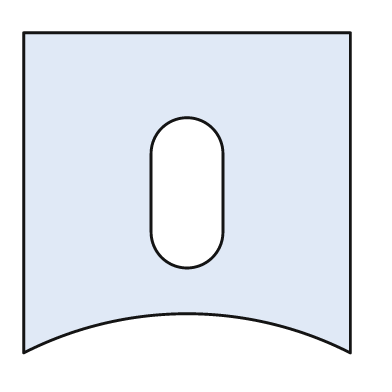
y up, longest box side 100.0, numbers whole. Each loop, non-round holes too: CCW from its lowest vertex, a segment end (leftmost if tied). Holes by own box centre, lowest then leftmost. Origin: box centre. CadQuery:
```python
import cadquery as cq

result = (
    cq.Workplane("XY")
    .moveTo(-50.0, -49.0)
    .threePointArc((0.0, -37.0), (50.0, -49.0))
    .lineTo(50.0, 49.0)
    .lineTo(-50.0, 49.0)
    .close()
    .moveTo(-11.0, -12.0)
    .threePointArc((0.0, -23.0), (11.0, -12.0))
    .lineTo(11.0, 12.0)
    .threePointArc((0.0, 23.0), (-11.0, 12.0))
    .close()
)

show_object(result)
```